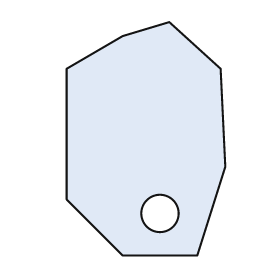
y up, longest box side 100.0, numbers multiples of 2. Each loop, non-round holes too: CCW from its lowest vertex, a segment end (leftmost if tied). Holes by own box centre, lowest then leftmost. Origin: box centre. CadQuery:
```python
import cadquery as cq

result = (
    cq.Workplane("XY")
    .moveTo(-10.0, -50.0)
    .lineTo(22.0, -50.0)
    .lineTo(34.0, -12.0)
    .lineTo(32.0, 30.0)
    .lineTo(10.0, 50.0)
    .lineTo(-10.0, 44.0)
    .lineTo(-34.0, 30.0)
    .lineTo(-34.0, -26.0)
    .close()
    .moveTo(6.0, -32.0)
    .circle(8.0)
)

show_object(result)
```